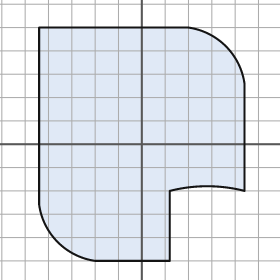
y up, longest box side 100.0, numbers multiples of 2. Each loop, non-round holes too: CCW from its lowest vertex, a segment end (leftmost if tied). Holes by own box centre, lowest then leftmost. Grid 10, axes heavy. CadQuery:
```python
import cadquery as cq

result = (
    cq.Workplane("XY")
    .moveTo(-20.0, -50.0)
    .lineTo(12.0, -50.0)
    .lineTo(12.0, -20.0)
    .threePointArc((28.0, -18.0), (44.0, -20.0))
    .lineTo(44.0, 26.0)
    .threePointArc((36.0, 42.0), (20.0, 50.0))
    .lineTo(-44.0, 50.0)
    .lineTo(-44.0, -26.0)
    .threePointArc((-36.0, -42.0), (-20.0, -50.0))
    .close()
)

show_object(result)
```